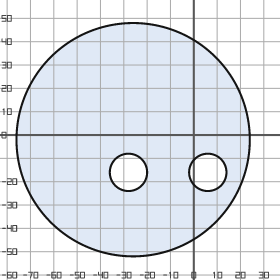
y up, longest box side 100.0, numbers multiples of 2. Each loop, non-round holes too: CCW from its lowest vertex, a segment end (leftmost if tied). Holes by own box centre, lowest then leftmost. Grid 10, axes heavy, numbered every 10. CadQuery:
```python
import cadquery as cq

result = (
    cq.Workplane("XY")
    .moveTo(-26.0, -2.0)
    .circle(50.0)
    .moveTo(-28.0, -16.0)
    .circle(8.0)
    .moveTo(6.0, -16.0)
    .circle(8.0)
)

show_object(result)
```